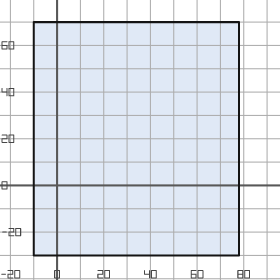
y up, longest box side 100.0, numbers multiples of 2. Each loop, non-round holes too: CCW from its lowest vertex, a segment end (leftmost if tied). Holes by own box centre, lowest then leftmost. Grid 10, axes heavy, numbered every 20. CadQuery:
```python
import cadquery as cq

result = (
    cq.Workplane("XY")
    .moveTo(-10.0, -30.0)
    .lineTo(78.0, -30.0)
    .lineTo(78.0, 70.0)
    .lineTo(-10.0, 70.0)
    .close()
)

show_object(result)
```